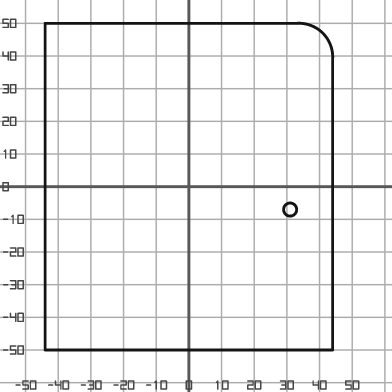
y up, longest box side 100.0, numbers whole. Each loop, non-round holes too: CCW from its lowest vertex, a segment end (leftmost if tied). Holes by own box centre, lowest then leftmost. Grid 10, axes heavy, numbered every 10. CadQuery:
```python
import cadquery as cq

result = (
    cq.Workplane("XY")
    .moveTo(-44.0, -50.0)
    .lineTo(44.0, -50.0)
    .lineTo(44.0, 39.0)
    .threePointArc((41.0, 47.0), (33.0, 50.0))
    .lineTo(-44.0, 50.0)
    .close()
    .moveTo(31.0, -7.0)
    .circle(2.0)
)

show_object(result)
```